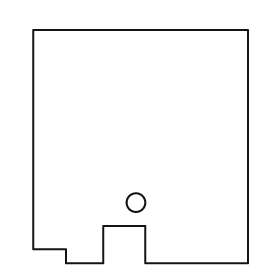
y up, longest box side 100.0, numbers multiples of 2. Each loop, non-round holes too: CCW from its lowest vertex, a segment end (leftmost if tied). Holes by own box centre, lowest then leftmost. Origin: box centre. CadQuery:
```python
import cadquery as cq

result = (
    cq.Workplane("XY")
    .moveTo(-32.0, -50.0)
    .lineTo(-16.0, -50.0)
    .lineTo(-16.0, -34.0)
    .lineTo(2.0, -34.0)
    .lineTo(2.0, -50.0)
    .lineTo(46.0, -50.0)
    .lineTo(46.0, 50.0)
    .lineTo(-46.0, 50.0)
    .lineTo(-46.0, -44.0)
    .lineTo(-32.0, -44.0)
    .close()
    .moveTo(-2.0, -24.0)
    .circle(4.0)
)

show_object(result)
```